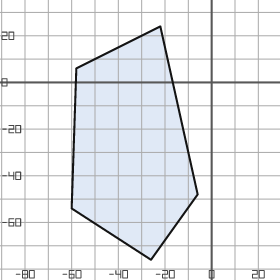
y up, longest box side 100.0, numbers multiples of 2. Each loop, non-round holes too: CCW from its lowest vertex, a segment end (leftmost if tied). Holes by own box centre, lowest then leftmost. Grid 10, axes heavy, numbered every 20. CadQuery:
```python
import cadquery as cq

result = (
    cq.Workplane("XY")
    .moveTo(-26.0, -76.0)
    .lineTo(-6.0, -48.0)
    .lineTo(-22.0, 24.0)
    .lineTo(-58.0, 6.0)
    .lineTo(-60.0, -54.0)
    .close()
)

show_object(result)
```